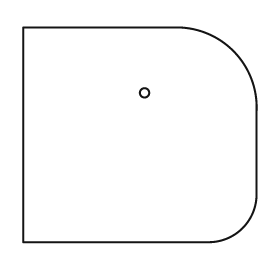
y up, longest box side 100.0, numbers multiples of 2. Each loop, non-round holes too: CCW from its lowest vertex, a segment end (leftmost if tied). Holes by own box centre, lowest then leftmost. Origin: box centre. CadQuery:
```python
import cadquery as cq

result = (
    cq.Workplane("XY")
    .moveTo(-50.0, -46.0)
    .lineTo(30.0, -46.0)
    .threePointArc((44.0, -40.0), (50.0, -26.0))
    .lineTo(50.0, 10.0)
    .threePointArc((40.0, 36.0), (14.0, 46.0))
    .lineTo(-50.0, 46.0)
    .close()
    .moveTo(2.0, 18.0)
    .circle(2.0)
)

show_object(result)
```